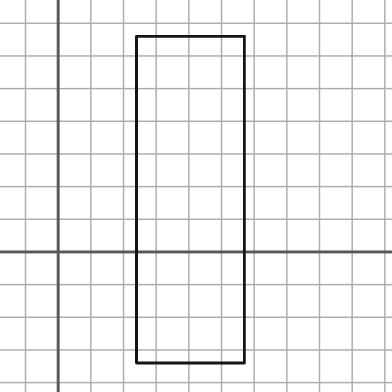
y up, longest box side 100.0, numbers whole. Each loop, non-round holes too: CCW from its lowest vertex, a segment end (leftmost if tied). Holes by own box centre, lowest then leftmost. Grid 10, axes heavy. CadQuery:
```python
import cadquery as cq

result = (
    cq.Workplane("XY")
    .moveTo(24.0, -34.0)
    .lineTo(57.0, -34.0)
    .lineTo(57.0, 66.0)
    .lineTo(24.0, 66.0)
    .close()
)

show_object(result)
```